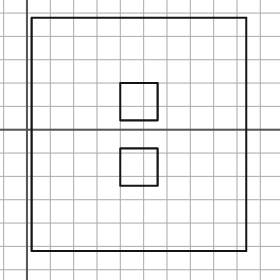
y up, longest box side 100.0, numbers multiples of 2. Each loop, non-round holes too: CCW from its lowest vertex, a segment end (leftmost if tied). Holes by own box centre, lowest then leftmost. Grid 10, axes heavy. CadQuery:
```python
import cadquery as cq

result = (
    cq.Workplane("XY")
    .moveTo(2.0, -52.0)
    .lineTo(94.0, -52.0)
    .lineTo(94.0, 48.0)
    .lineTo(2.0, 48.0)
    .close()
    .moveTo(40.0, -24.0)
    .lineTo(56.0, -24.0)
    .lineTo(56.0, -8.0)
    .lineTo(40.0, -8.0)
    .close()
    .moveTo(40.0, 4.0)
    .lineTo(56.0, 4.0)
    .lineTo(56.0, 20.0)
    .lineTo(40.0, 20.0)
    .close()
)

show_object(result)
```